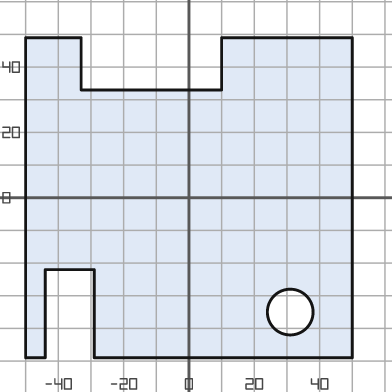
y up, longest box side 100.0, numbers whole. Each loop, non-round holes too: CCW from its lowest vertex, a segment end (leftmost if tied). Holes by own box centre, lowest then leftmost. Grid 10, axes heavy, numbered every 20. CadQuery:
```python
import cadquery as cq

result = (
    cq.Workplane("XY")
    .moveTo(-50.0, -49.0)
    .lineTo(-44.0, -49.0)
    .lineTo(-44.0, -22.0)
    .lineTo(-29.0, -22.0)
    .lineTo(-29.0, -49.0)
    .lineTo(50.0, -49.0)
    .lineTo(50.0, 49.0)
    .lineTo(10.0, 49.0)
    .lineTo(10.0, 33.0)
    .lineTo(-33.0, 33.0)
    .lineTo(-33.0, 49.0)
    .lineTo(-50.0, 49.0)
    .close()
    .moveTo(31.0, -35.0)
    .circle(7.0)
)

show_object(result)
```